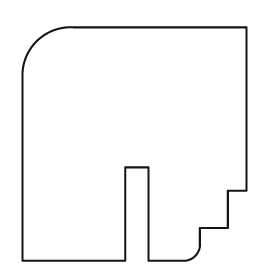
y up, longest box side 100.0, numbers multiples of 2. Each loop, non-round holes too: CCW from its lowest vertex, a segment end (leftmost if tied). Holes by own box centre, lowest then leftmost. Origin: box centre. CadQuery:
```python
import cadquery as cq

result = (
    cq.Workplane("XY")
    .moveTo(-48.0, -50.0)
    .lineTo(-4.0, -50.0)
    .lineTo(-4.0, -10.0)
    .lineTo(6.0, -10.0)
    .lineTo(6.0, -50.0)
    .lineTo(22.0, -50.0)
    .threePointArc((26.0, -48.0), (28.0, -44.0))
    .lineTo(28.0, -36.0)
    .lineTo(40.0, -36.0)
    .lineTo(40.0, -20.0)
    .lineTo(48.0, -20.0)
    .lineTo(48.0, 50.0)
    .lineTo(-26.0, 50.0)
    .threePointArc((-42.0, 44.0), (-48.0, 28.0))
    .close()
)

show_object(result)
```